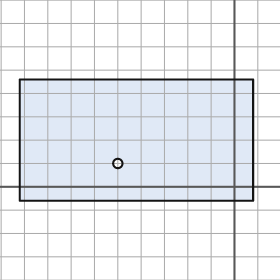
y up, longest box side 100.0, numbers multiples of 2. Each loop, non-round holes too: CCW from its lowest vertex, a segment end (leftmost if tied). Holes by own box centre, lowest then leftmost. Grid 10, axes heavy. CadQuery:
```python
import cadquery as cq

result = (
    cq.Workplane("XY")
    .moveTo(-92.0, -6.0)
    .lineTo(8.0, -6.0)
    .lineTo(8.0, 46.0)
    .lineTo(-92.0, 46.0)
    .close()
    .moveTo(-50.0, 10.0)
    .circle(2.0)
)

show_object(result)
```